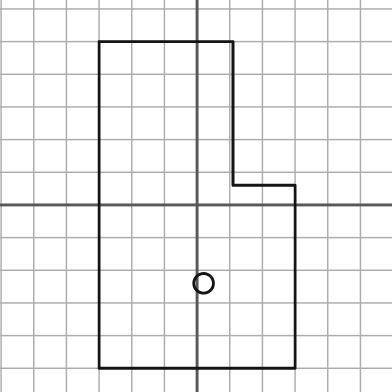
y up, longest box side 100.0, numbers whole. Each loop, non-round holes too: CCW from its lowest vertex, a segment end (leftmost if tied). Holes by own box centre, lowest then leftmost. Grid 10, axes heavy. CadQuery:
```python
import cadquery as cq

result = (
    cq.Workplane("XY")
    .moveTo(-30.0, -50.0)
    .lineTo(30.0, -50.0)
    .lineTo(30.0, 6.0)
    .lineTo(11.0, 6.0)
    .lineTo(11.0, 50.0)
    .lineTo(-30.0, 50.0)
    .close()
    .moveTo(2.0, -24.0)
    .circle(3.0)
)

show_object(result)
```